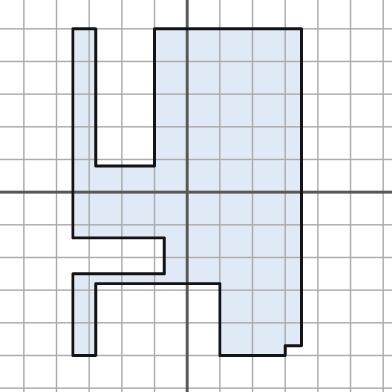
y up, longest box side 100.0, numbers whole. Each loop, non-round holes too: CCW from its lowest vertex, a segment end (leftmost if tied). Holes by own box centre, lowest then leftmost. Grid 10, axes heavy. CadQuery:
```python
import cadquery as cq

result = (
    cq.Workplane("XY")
    .moveTo(-35.0, -50.0)
    .lineTo(-28.0, -50.0)
    .lineTo(-28.0, -28.0)
    .lineTo(10.0, -28.0)
    .lineTo(10.0, -50.0)
    .lineTo(30.0, -50.0)
    .lineTo(30.0, -47.0)
    .lineTo(35.0, -47.0)
    .lineTo(35.0, 50.0)
    .lineTo(-10.0, 50.0)
    .lineTo(-10.0, 8.0)
    .lineTo(-28.0, 8.0)
    .lineTo(-28.0, 50.0)
    .lineTo(-35.0, 50.0)
    .lineTo(-35.0, -14.0)
    .lineTo(-7.0, -14.0)
    .lineTo(-7.0, -25.0)
    .lineTo(-35.0, -25.0)
    .close()
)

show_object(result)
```